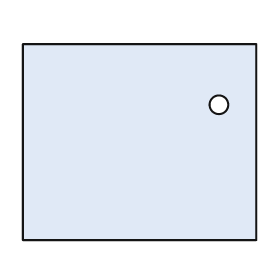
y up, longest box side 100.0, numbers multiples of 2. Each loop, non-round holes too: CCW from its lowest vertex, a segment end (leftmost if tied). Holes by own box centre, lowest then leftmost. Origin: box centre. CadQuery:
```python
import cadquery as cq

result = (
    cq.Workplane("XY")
    .moveTo(-50.0, -42.0)
    .lineTo(50.0, -42.0)
    .lineTo(50.0, 42.0)
    .lineTo(-50.0, 42.0)
    .close()
    .moveTo(34.0, 16.0)
    .circle(4.0)
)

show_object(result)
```